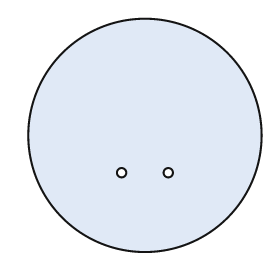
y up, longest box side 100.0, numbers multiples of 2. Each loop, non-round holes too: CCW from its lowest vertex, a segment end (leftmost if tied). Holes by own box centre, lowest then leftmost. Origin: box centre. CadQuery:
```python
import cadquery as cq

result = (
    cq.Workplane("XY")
    .moveTo(0.0, 0.0)
    .circle(50.0)
    .moveTo(-10.0, -16.0)
    .circle(2.0)
    .moveTo(10.0, -16.0)
    .circle(2.0)
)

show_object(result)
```